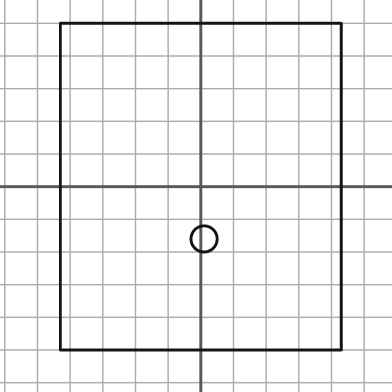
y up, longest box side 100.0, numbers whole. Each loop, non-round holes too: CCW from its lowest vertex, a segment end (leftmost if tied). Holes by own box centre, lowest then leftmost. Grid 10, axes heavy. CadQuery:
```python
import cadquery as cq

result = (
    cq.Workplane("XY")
    .moveTo(-43.0, -50.0)
    .lineTo(43.0, -50.0)
    .lineTo(43.0, 50.0)
    .lineTo(-43.0, 50.0)
    .close()
    .moveTo(1.0, -16.0)
    .circle(4.0)
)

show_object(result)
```